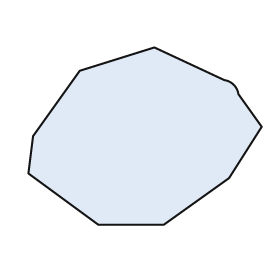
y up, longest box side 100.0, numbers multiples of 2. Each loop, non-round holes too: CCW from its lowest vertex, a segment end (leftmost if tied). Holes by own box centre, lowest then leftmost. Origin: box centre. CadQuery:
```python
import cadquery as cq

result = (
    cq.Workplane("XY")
    .moveTo(-20.0, -38.0)
    .lineTo(8.0, -38.0)
    .lineTo(36.0, -18.0)
    .lineTo(50.0, 4.0)
    .lineTo(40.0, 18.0)
    .threePointArc((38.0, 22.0), (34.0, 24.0))
    .lineTo(4.0, 38.0)
    .lineTo(-28.0, 28.0)
    .lineTo(-48.0, 0.0)
    .lineTo(-50.0, -16.0)
    .close()
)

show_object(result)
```